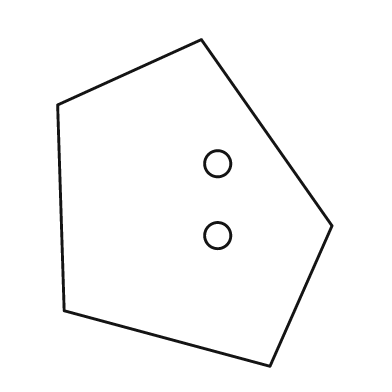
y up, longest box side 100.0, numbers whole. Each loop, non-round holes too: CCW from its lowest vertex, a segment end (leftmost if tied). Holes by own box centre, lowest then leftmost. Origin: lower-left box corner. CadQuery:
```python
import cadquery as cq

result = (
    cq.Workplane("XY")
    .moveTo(65.0, 0.0)
    .lineTo(84.0, 43.0)
    .lineTo(44.0, 100.0)
    .lineTo(0.0, 80.0)
    .lineTo(2.0, 17.0)
    .close()
    .moveTo(49.0, 40.0)
    .circle(4.0)
    .moveTo(49.0, 62.0)
    .circle(4.0)
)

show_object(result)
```